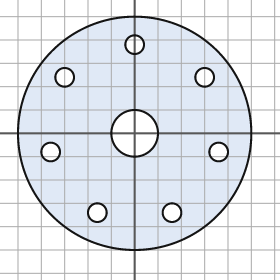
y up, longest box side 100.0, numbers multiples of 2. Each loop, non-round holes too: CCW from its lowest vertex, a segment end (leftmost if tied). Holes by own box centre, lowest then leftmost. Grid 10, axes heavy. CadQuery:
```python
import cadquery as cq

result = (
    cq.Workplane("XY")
    .moveTo(0.0, 0.0)
    .circle(50.0)
    .moveTo(-16.0, -34.0)
    .circle(4.0)
    .moveTo(16.0, -34.0)
    .circle(4.0)
    .moveTo(-36.0, -8.0)
    .circle(4.0)
    .moveTo(36.0, -8.0)
    .circle(4.0)
    .moveTo(0.0, 0.0)
    .circle(10.0)
    .moveTo(-30.0, 24.0)
    .circle(4.0)
    .moveTo(30.0, 24.0)
    .circle(4.0)
    .moveTo(0.0, 38.0)
    .circle(4.0)
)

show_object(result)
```